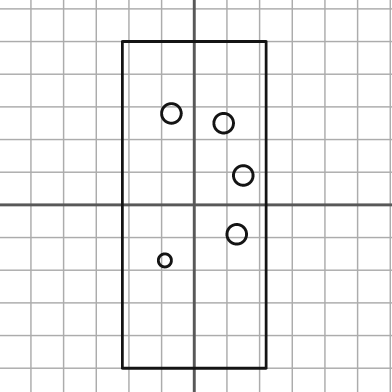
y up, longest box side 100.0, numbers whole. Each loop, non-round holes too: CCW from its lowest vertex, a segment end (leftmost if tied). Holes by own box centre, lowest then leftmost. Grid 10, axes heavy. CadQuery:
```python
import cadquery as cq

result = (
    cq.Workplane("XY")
    .moveTo(-22.0, -50.0)
    .lineTo(22.0, -50.0)
    .lineTo(22.0, 50.0)
    .lineTo(-22.0, 50.0)
    .close()
    .moveTo(-9.0, -17.0)
    .circle(2.0)
    .moveTo(13.0, -9.0)
    .circle(3.0)
    .moveTo(15.0, 9.0)
    .circle(3.0)
    .moveTo(9.0, 25.0)
    .circle(3.0)
    .moveTo(-7.0, 28.0)
    .circle(3.0)
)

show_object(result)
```